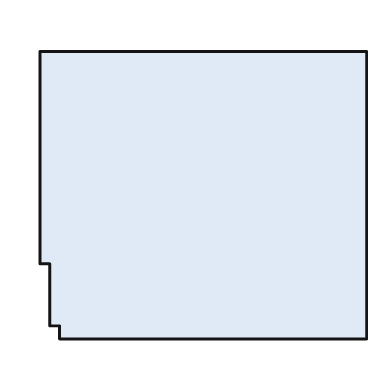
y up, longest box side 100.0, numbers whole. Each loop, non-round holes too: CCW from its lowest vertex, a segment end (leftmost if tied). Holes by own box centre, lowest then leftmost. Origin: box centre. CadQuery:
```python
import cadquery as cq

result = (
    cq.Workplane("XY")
    .moveTo(-44.0, -44.0)
    .lineTo(50.0, -44.0)
    .lineTo(50.0, 44.0)
    .lineTo(-50.0, 44.0)
    .lineTo(-50.0, -21.0)
    .lineTo(-47.0, -21.0)
    .lineTo(-47.0, -40.0)
    .lineTo(-44.0, -40.0)
    .close()
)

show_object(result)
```